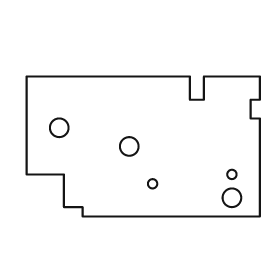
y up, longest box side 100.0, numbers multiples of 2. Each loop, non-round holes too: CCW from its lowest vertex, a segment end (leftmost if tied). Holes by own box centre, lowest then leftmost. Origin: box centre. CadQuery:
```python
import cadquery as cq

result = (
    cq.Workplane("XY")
    .moveTo(-26.0, -30.0)
    .lineTo(50.0, -30.0)
    .lineTo(50.0, 12.0)
    .lineTo(46.0, 12.0)
    .lineTo(46.0, 20.0)
    .lineTo(50.0, 20.0)
    .lineTo(50.0, 30.0)
    .lineTo(26.0, 30.0)
    .lineTo(26.0, 20.0)
    .lineTo(20.0, 20.0)
    .lineTo(20.0, 30.0)
    .lineTo(-50.0, 30.0)
    .lineTo(-50.0, -12.0)
    .lineTo(-34.0, -12.0)
    .lineTo(-34.0, -26.0)
    .lineTo(-26.0, -26.0)
    .close()
    .moveTo(38.0, -22.0)
    .circle(4.0)
    .moveTo(4.0, -16.0)
    .circle(2.0)
    .moveTo(38.0, -12.0)
    .circle(2.0)
    .moveTo(-6.0, 0.0)
    .circle(4.0)
    .moveTo(-36.0, 8.0)
    .circle(4.0)
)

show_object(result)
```